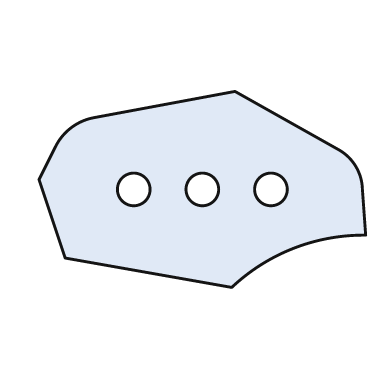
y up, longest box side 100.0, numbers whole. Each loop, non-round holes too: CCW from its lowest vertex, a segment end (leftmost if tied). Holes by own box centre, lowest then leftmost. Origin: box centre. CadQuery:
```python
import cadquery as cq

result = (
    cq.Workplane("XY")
    .moveTo(9.0, -30.0)
    .threePointArc((28.0, -18.0), (50.0, -14.0))
    .lineTo(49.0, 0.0)
    .threePointArc((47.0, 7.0), (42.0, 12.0))
    .lineTo(10.0, 30.0)
    .lineTo(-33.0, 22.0)
    .threePointArc((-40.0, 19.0), (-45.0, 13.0))
    .lineTo(-50.0, 3.0)
    .lineTo(-42.0, -21.0)
    .close()
    .moveTo(-21.0, 0.0)
    .circle(5.0)
    .moveTo(0.0, 0.0)
    .circle(5.0)
    .moveTo(21.0, 0.0)
    .circle(5.0)
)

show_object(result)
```